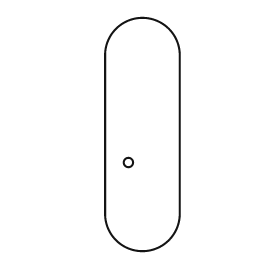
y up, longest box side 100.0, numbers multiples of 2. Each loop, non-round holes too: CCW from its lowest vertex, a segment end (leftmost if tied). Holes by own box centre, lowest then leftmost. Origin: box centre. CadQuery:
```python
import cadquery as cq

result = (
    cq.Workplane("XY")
    .moveTo(-16.0, -34.0)
    .threePointArc((0.0, -50.0), (16.0, -34.0))
    .lineTo(16.0, 34.0)
    .threePointArc((0.0, 50.0), (-16.0, 34.0))
    .close()
    .moveTo(-6.0, -12.0)
    .circle(2.0)
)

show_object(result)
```